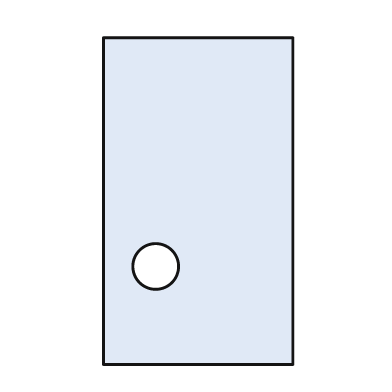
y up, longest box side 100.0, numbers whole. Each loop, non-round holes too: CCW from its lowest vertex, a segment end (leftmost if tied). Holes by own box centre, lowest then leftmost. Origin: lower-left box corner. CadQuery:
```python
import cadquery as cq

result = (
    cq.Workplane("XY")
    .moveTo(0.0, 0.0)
    .lineTo(58.0, 0.0)
    .lineTo(58.0, 100.0)
    .lineTo(0.0, 100.0)
    .close()
    .moveTo(16.0, 30.0)
    .circle(7.0)
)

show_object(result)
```